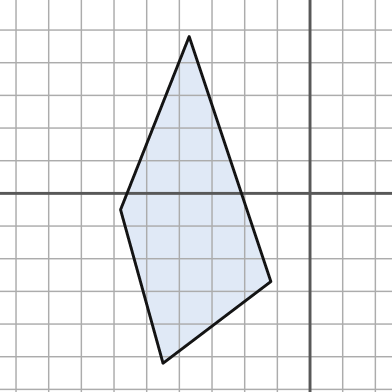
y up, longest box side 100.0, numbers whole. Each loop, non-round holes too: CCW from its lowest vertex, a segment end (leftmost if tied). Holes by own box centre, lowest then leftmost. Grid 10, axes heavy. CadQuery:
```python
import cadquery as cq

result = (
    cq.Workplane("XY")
    .moveTo(-45.0, -52.0)
    .lineTo(-12.0, -27.0)
    .lineTo(-37.0, 48.0)
    .lineTo(-58.0, -5.0)
    .close()
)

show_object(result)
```